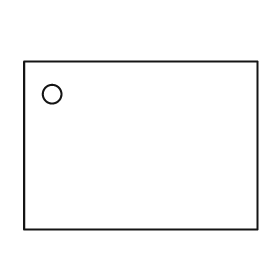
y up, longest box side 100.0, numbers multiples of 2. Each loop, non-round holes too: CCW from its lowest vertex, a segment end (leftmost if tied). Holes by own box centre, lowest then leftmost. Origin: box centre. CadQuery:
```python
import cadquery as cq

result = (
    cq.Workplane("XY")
    .moveTo(-50.0, -36.0)
    .lineTo(50.0, -36.0)
    .lineTo(50.0, 36.0)
    .lineTo(-50.0, 36.0)
    .close()
    .moveTo(-38.0, 22.0)
    .circle(4.0)
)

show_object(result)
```